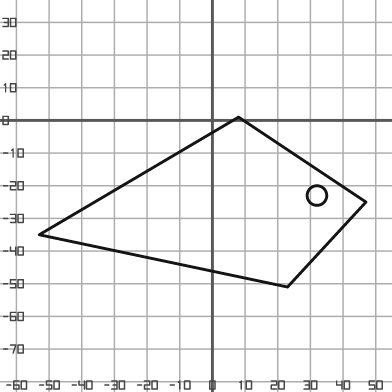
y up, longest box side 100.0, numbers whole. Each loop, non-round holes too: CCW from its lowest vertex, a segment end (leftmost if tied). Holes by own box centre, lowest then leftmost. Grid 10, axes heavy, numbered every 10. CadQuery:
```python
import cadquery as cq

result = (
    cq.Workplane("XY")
    .moveTo(23.0, -51.0)
    .lineTo(47.0, -25.0)
    .lineTo(8.0, 1.0)
    .lineTo(-53.0, -35.0)
    .close()
    .moveTo(32.0, -23.0)
    .circle(3.0)
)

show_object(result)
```